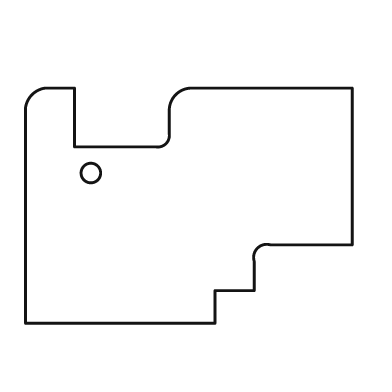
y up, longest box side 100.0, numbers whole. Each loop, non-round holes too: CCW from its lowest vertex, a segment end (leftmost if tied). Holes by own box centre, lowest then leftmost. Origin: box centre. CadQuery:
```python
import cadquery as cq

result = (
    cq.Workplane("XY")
    .moveTo(-50.0, -36.0)
    .lineTo(8.0, -36.0)
    .lineTo(8.0, -26.0)
    .lineTo(20.0, -26.0)
    .lineTo(20.0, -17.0)
    .threePointArc((21.0, -13.0), (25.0, -12.0))
    .lineTo(50.0, -12.0)
    .lineTo(50.0, 36.0)
    .lineTo(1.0, 36.0)
    .threePointArc((-4.0, 34.0), (-6.0, 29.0))
    .lineTo(-6.0, 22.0)
    .threePointArc((-7.0, 19.0), (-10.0, 18.0))
    .lineTo(-35.0, 18.0)
    .lineTo(-35.0, 36.0)
    .lineTo(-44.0, 36.0)
    .threePointArc((-48.0, 34.0), (-50.0, 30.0))
    .close()
    .moveTo(-30.0, 10.0)
    .circle(3.0)
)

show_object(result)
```